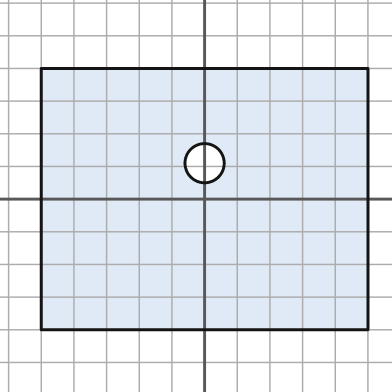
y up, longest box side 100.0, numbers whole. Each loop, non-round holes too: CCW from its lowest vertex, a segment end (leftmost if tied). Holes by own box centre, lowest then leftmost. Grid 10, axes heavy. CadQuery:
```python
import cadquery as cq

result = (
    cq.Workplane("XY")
    .moveTo(-50.0, -40.0)
    .lineTo(50.0, -40.0)
    .lineTo(50.0, 40.0)
    .lineTo(-50.0, 40.0)
    .close()
    .moveTo(0.0, 11.0)
    .circle(6.0)
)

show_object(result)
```